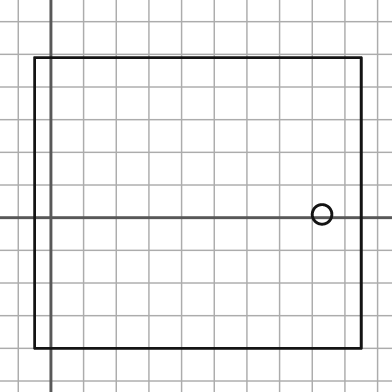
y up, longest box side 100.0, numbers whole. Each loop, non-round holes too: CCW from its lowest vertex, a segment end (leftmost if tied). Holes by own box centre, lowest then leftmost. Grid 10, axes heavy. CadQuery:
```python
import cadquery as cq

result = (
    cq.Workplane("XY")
    .moveTo(-5.0, -40.0)
    .lineTo(95.0, -40.0)
    .lineTo(95.0, 49.0)
    .lineTo(-5.0, 49.0)
    .close()
    .moveTo(83.0, 1.0)
    .circle(3.0)
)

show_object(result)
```